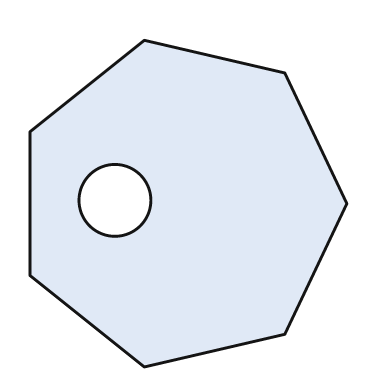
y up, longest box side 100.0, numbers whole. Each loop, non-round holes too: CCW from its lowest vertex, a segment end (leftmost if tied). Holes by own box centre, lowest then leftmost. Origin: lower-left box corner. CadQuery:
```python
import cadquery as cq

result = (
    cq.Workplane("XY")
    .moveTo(35.0, 0.0)
    .lineTo(78.0, 10.0)
    .lineTo(97.0, 50.0)
    .lineTo(78.0, 90.0)
    .lineTo(35.0, 100.0)
    .lineTo(0.0, 72.0)
    .lineTo(0.0, 28.0)
    .close()
    .moveTo(26.0, 51.0)
    .circle(11.0)
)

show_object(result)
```